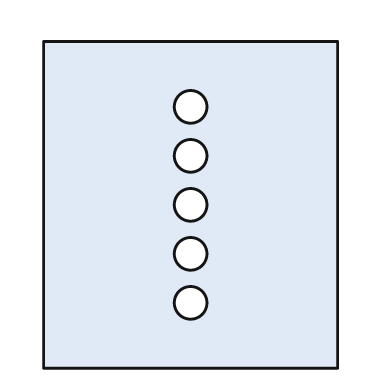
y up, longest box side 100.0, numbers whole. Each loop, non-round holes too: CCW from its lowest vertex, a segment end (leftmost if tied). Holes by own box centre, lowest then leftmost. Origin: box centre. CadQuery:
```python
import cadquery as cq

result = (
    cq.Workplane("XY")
    .moveTo(-45.0, -50.0)
    .lineTo(45.0, -50.0)
    .lineTo(45.0, 50.0)
    .lineTo(-45.0, 50.0)
    .close()
    .moveTo(0.0, -30.0)
    .circle(5.0)
    .moveTo(0.0, -15.0)
    .circle(5.0)
    .moveTo(0.0, 0.0)
    .circle(5.0)
    .moveTo(0.0, 15.0)
    .circle(5.0)
    .moveTo(0.0, 30.0)
    .circle(5.0)
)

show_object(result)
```